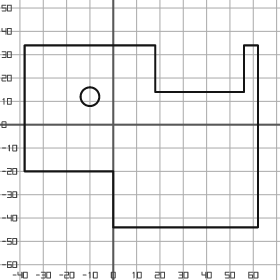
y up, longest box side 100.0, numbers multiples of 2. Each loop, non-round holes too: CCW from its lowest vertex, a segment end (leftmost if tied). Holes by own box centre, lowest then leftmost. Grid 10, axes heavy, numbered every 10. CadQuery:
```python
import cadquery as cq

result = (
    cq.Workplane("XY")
    .moveTo(0.0, -44.0)
    .lineTo(62.0, -44.0)
    .lineTo(62.0, 34.0)
    .lineTo(56.0, 34.0)
    .lineTo(56.0, 14.0)
    .lineTo(18.0, 14.0)
    .lineTo(18.0, 34.0)
    .lineTo(-38.0, 34.0)
    .lineTo(-38.0, -20.0)
    .lineTo(0.0, -20.0)
    .close()
    .moveTo(-10.0, 12.0)
    .circle(4.0)
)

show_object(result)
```